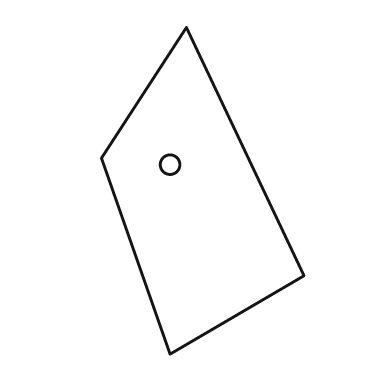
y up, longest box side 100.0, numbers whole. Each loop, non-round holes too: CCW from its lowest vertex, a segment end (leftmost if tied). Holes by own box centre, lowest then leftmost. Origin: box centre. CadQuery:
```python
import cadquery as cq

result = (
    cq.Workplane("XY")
    .moveTo(-10.0, -50.0)
    .lineTo(31.0, -26.0)
    .lineTo(-5.0, 50.0)
    .lineTo(-31.0, 10.0)
    .close()
    .moveTo(-10.0, 8.0)
    .circle(3.0)
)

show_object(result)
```